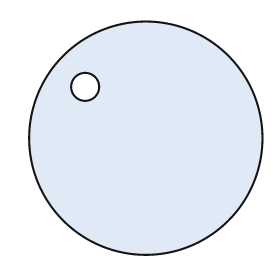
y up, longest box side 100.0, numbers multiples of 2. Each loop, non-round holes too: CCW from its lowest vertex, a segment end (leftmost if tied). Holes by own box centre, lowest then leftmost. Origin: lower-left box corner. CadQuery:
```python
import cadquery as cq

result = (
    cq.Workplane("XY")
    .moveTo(50.0, 50.0)
    .circle(50.0)
    .moveTo(24.0, 72.0)
    .circle(6.0)
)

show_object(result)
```